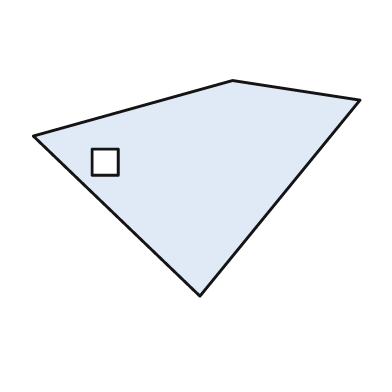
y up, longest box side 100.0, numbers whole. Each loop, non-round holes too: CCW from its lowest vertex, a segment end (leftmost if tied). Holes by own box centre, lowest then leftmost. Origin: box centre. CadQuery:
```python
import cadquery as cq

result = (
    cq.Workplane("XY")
    .moveTo(1.0, -33.0)
    .lineTo(50.0, 27.0)
    .lineTo(11.0, 33.0)
    .lineTo(-50.0, 16.0)
    .close()
    .moveTo(-32.0, 4.0)
    .lineTo(-24.0, 4.0)
    .lineTo(-24.0, 12.0)
    .lineTo(-32.0, 12.0)
    .close()
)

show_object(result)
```